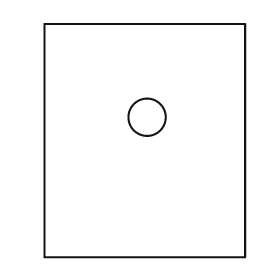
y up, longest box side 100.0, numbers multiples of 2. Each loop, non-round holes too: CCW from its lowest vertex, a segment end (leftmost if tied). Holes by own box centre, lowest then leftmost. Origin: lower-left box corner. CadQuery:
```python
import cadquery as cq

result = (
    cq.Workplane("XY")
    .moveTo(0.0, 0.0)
    .lineTo(86.0, 0.0)
    .lineTo(86.0, 100.0)
    .lineTo(0.0, 100.0)
    .close()
    .moveTo(44.0, 60.0)
    .circle(8.0)
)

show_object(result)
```